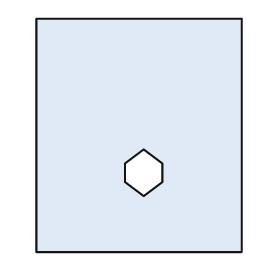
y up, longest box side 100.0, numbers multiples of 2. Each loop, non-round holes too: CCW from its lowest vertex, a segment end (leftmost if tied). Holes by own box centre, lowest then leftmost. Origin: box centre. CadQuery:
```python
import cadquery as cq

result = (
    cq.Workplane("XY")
    .moveTo(-44.0, -50.0)
    .lineTo(44.0, -50.0)
    .lineTo(44.0, 50.0)
    .lineTo(-44.0, 50.0)
    .close()
    .moveTo(2.0, -26.0)
    .lineTo(10.0, -20.0)
    .lineTo(10.0, -12.0)
    .lineTo(2.0, -6.0)
    .lineTo(-6.0, -12.0)
    .lineTo(-6.0, -20.0)
    .close()
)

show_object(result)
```